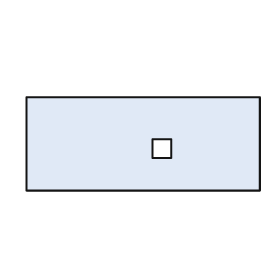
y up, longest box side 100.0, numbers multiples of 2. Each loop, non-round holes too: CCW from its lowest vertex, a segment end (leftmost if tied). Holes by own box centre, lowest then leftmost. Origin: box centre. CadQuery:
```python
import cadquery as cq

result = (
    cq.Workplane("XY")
    .moveTo(-50.0, -20.0)
    .lineTo(50.0, -20.0)
    .lineTo(50.0, 20.0)
    .lineTo(-50.0, 20.0)
    .close()
    .moveTo(4.0, -6.0)
    .lineTo(12.0, -6.0)
    .lineTo(12.0, 2.0)
    .lineTo(4.0, 2.0)
    .close()
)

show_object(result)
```